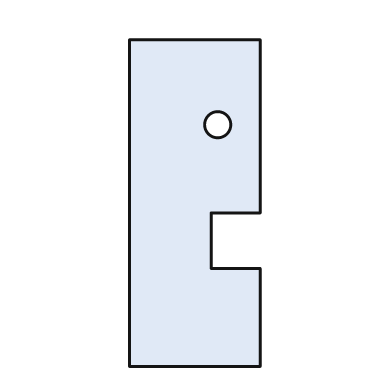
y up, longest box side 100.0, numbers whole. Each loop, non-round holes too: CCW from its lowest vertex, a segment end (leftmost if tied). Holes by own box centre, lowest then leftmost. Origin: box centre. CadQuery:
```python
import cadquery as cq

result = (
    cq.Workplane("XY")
    .moveTo(-20.0, -50.0)
    .lineTo(20.0, -50.0)
    .lineTo(20.0, -20.0)
    .lineTo(5.0, -20.0)
    .lineTo(5.0, -3.0)
    .lineTo(20.0, -3.0)
    .lineTo(20.0, 50.0)
    .lineTo(-20.0, 50.0)
    .close()
    .moveTo(7.0, 24.0)
    .circle(4.0)
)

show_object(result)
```